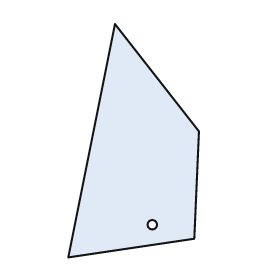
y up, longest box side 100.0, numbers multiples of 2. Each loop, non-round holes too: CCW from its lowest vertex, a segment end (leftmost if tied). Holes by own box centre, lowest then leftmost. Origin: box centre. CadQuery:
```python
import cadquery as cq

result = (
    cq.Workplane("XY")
    .moveTo(-28.0, -50.0)
    .lineTo(26.0, -42.0)
    .lineTo(28.0, 4.0)
    .lineTo(-8.0, 50.0)
    .close()
    .moveTo(8.0, -36.0)
    .circle(2.0)
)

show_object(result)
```